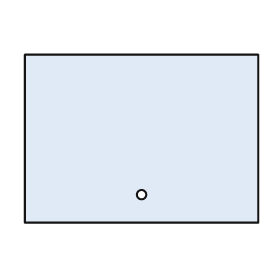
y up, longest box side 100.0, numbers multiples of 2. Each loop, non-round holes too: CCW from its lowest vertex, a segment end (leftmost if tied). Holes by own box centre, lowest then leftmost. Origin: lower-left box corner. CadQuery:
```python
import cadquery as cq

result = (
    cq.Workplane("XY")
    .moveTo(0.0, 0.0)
    .lineTo(100.0, 0.0)
    .lineTo(100.0, 72.0)
    .lineTo(0.0, 72.0)
    .close()
    .moveTo(50.0, 12.0)
    .circle(2.0)
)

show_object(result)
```